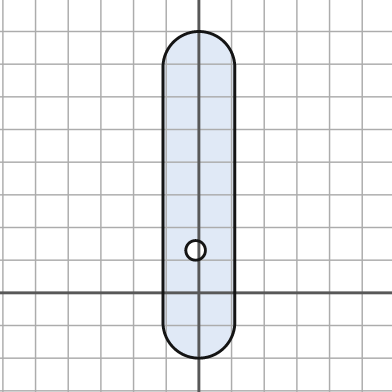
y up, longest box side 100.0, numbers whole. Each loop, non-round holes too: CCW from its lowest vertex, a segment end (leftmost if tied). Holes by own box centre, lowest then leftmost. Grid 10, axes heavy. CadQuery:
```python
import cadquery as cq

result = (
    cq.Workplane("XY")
    .moveTo(-11.0, -9.0)
    .threePointArc((0.0, -20.0), (11.0, -9.0))
    .lineTo(11.0, 69.0)
    .threePointArc((0.0, 80.0), (-11.0, 69.0))
    .close()
    .moveTo(-1.0, 13.0)
    .circle(3.0)
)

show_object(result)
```